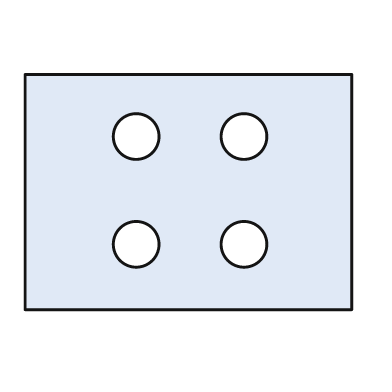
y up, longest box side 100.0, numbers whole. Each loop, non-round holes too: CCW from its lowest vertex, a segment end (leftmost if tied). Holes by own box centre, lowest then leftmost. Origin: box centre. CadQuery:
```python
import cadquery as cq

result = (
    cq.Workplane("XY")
    .moveTo(-50.0, -36.0)
    .lineTo(50.0, -36.0)
    .lineTo(50.0, 36.0)
    .lineTo(-50.0, 36.0)
    .close()
    .moveTo(-16.0, -16.0)
    .circle(7.0)
    .moveTo(17.0, -16.0)
    .circle(7.0)
    .moveTo(-16.0, 17.0)
    .circle(7.0)
    .moveTo(17.0, 17.0)
    .circle(7.0)
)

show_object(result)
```